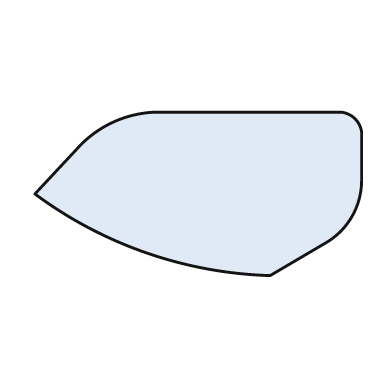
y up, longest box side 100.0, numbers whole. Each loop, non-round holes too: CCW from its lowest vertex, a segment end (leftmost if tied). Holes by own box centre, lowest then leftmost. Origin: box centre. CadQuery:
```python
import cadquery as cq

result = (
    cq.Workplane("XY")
    .moveTo(22.0, -25.0)
    .lineTo(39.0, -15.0)
    .threePointArc((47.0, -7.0), (50.0, 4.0))
    .lineTo(50.0, 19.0)
    .threePointArc((48.0, 23.0), (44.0, 25.0))
    .lineTo(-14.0, 25.0)
    .threePointArc((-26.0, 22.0), (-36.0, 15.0))
    .lineTo(-50.0, 0.0)
    .threePointArc((-16.0, -18.0), (22.0, -25.0))
    .close()
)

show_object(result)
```